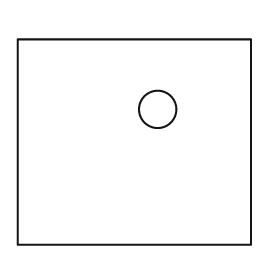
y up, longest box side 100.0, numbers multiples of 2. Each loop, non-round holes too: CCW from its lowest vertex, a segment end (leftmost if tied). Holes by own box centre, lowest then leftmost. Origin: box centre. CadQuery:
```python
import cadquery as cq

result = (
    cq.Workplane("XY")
    .moveTo(-50.0, -44.0)
    .lineTo(50.0, -44.0)
    .lineTo(50.0, 44.0)
    .lineTo(-50.0, 44.0)
    .close()
    .moveTo(10.0, 14.0)
    .circle(8.0)
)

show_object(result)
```